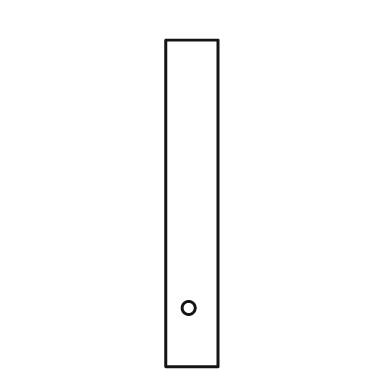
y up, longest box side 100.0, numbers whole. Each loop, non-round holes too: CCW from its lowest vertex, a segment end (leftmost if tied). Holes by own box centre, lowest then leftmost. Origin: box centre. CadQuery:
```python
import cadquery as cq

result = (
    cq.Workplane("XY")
    .moveTo(-8.0, -50.0)
    .lineTo(8.0, -50.0)
    .lineTo(8.0, 50.0)
    .lineTo(-8.0, 50.0)
    .close()
    .moveTo(-1.0, -32.0)
    .circle(2.0)
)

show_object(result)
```